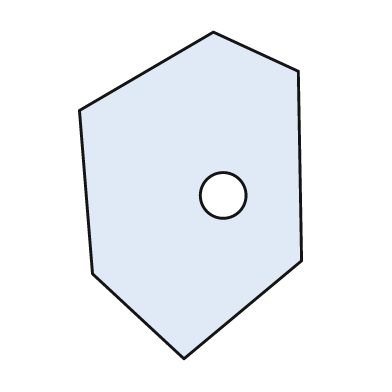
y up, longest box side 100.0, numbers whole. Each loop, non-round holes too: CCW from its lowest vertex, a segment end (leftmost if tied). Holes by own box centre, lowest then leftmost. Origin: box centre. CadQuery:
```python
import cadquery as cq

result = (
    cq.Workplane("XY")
    .moveTo(-2.0, -50.0)
    .lineTo(34.0, -20.0)
    .lineTo(33.0, 38.0)
    .lineTo(7.0, 50.0)
    .lineTo(-34.0, 26.0)
    .lineTo(-30.0, -24.0)
    .close()
    .moveTo(10.0, 0.0)
    .circle(7.0)
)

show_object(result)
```